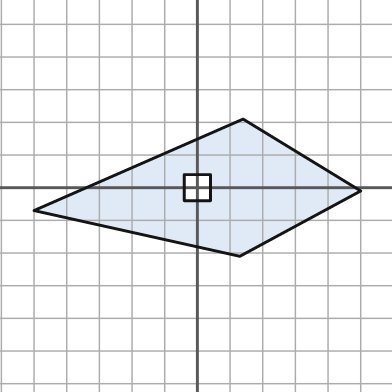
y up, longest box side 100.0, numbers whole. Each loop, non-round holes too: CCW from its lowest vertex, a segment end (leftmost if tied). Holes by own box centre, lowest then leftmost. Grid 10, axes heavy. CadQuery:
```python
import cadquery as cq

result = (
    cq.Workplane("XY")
    .moveTo(13.0, -21.0)
    .lineTo(50.0, -1.0)
    .lineTo(14.0, 21.0)
    .lineTo(-50.0, -7.0)
    .close()
    .moveTo(-4.0, -4.0)
    .lineTo(4.0, -4.0)
    .lineTo(4.0, 4.0)
    .lineTo(-4.0, 4.0)
    .close()
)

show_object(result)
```